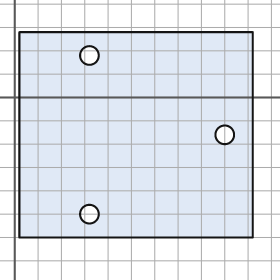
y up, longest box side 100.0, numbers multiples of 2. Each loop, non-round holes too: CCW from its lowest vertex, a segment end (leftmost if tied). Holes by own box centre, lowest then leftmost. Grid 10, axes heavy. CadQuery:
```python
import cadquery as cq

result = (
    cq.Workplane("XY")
    .moveTo(2.0, -60.0)
    .lineTo(102.0, -60.0)
    .lineTo(102.0, 28.0)
    .lineTo(2.0, 28.0)
    .close()
    .moveTo(32.0, -50.0)
    .circle(4.0)
    .moveTo(90.0, -16.0)
    .circle(4.0)
    .moveTo(32.0, 18.0)
    .circle(4.0)
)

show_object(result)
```